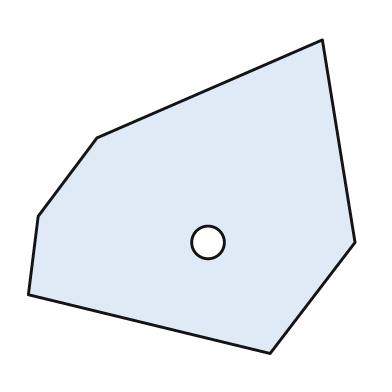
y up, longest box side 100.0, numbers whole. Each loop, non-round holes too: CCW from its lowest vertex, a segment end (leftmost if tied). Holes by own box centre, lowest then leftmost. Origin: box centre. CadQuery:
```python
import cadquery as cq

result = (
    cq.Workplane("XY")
    .moveTo(24.0, -48.0)
    .lineTo(50.0, -14.0)
    .lineTo(40.0, 48.0)
    .lineTo(-29.0, 18.0)
    .lineTo(-47.0, -6.0)
    .lineTo(-50.0, -30.0)
    .close()
    .moveTo(5.0, -14.0)
    .circle(5.0)
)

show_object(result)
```